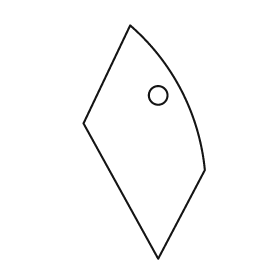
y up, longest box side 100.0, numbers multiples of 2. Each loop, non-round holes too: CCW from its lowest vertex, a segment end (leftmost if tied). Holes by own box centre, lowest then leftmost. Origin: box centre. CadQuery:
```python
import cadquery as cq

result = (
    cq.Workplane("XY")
    .moveTo(6.0, -50.0)
    .lineTo(26.0, -12.0)
    .threePointArc((16.0, 22.0), (-6.0, 50.0))
    .lineTo(-26.0, 8.0)
    .close()
    .moveTo(6.0, 20.0)
    .circle(4.0)
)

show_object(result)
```